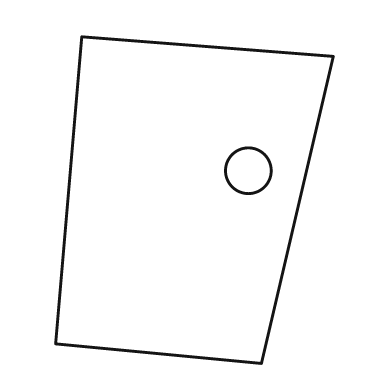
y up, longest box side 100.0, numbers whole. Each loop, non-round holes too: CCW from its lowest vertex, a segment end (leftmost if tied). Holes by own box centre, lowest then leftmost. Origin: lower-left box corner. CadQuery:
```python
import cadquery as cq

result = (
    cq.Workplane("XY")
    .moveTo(63.0, 0.0)
    .lineTo(85.0, 94.0)
    .lineTo(8.0, 100.0)
    .lineTo(0.0, 6.0)
    .close()
    .moveTo(59.0, 59.0)
    .circle(7.0)
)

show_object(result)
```